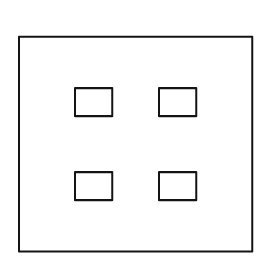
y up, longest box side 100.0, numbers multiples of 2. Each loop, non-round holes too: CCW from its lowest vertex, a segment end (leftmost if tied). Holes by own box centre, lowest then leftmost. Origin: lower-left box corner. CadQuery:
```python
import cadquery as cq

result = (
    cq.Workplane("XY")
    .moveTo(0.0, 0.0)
    .lineTo(100.0, 0.0)
    .lineTo(100.0, 92.0)
    .lineTo(0.0, 92.0)
    .close()
    .moveTo(24.0, 22.0)
    .lineTo(40.0, 22.0)
    .lineTo(40.0, 34.0)
    .lineTo(24.0, 34.0)
    .close()
    .moveTo(60.0, 22.0)
    .lineTo(76.0, 22.0)
    .lineTo(76.0, 34.0)
    .lineTo(60.0, 34.0)
    .close()
    .moveTo(24.0, 58.0)
    .lineTo(40.0, 58.0)
    .lineTo(40.0, 70.0)
    .lineTo(24.0, 70.0)
    .close()
    .moveTo(60.0, 58.0)
    .lineTo(76.0, 58.0)
    .lineTo(76.0, 70.0)
    .lineTo(60.0, 70.0)
    .close()
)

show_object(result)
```